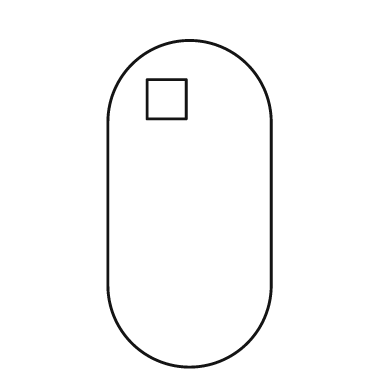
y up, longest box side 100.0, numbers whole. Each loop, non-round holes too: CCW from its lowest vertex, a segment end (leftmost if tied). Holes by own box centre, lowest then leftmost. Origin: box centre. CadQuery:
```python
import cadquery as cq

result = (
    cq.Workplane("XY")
    .moveTo(-25.0, -25.0)
    .threePointArc((0.0, -50.0), (25.0, -25.0))
    .lineTo(25.0, 25.0)
    .threePointArc((0.0, 50.0), (-25.0, 25.0))
    .close()
    .moveTo(-13.0, 26.0)
    .lineTo(-1.0, 26.0)
    .lineTo(-1.0, 38.0)
    .lineTo(-13.0, 38.0)
    .close()
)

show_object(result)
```